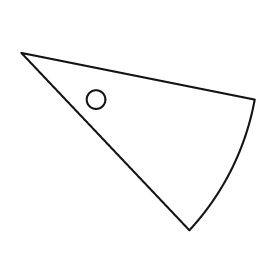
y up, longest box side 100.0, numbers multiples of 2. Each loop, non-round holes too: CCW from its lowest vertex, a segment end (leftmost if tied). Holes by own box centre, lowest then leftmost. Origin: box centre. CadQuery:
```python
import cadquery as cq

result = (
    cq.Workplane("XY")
    .moveTo(22.0, -38.0)
    .threePointArc((40.0, -12.0), (50.0, 18.0))
    .lineTo(-50.0, 38.0)
    .close()
    .moveTo(-18.0, 18.0)
    .circle(4.0)
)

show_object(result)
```